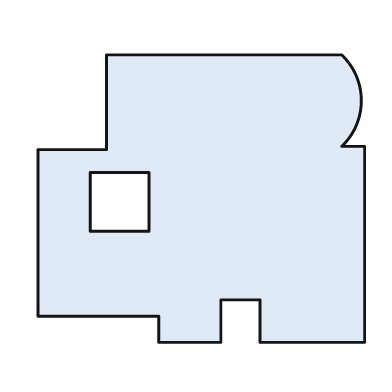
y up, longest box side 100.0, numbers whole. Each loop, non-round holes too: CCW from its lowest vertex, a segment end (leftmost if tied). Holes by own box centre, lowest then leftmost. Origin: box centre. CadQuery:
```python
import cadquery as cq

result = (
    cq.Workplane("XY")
    .moveTo(-13.0, -44.0)
    .lineTo(6.0, -44.0)
    .lineTo(6.0, -31.0)
    .lineTo(18.0, -31.0)
    .lineTo(18.0, -44.0)
    .lineTo(50.0, -44.0)
    .lineTo(50.0, 16.0)
    .lineTo(43.0, 16.0)
    .threePointArc((49.0, 30.0), (43.0, 44.0))
    .lineTo(-29.0, 44.0)
    .lineTo(-29.0, 15.0)
    .lineTo(-50.0, 15.0)
    .lineTo(-50.0, -36.0)
    .lineTo(-13.0, -36.0)
    .close()
    .moveTo(-34.0, -10.0)
    .lineTo(-16.0, -10.0)
    .lineTo(-16.0, 8.0)
    .lineTo(-34.0, 8.0)
    .close()
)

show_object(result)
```